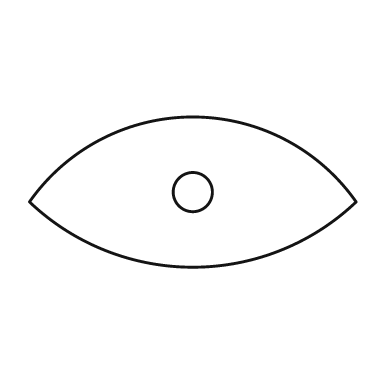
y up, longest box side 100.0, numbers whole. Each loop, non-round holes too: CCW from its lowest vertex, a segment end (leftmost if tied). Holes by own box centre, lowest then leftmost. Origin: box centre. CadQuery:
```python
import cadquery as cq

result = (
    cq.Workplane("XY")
    .moveTo(-50.0, -3.0)
    .threePointArc((0.0, -23.0), (50.0, -3.0))
    .threePointArc((0.0, 23.0), (-50.0, -3.0))
    .close()
    .moveTo(0.0, 0.0)
    .circle(6.0)
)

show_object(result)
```